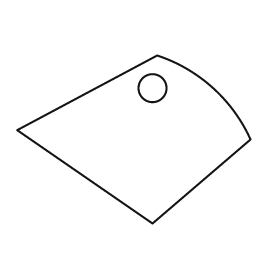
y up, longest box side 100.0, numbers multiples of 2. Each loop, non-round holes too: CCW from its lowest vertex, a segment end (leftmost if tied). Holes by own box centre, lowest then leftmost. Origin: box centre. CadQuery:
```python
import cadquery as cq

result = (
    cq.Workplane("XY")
    .moveTo(8.0, -36.0)
    .lineTo(50.0, 0.0)
    .threePointArc((34.0, 22.0), (10.0, 36.0))
    .lineTo(-50.0, 4.0)
    .close()
    .moveTo(8.0, 22.0)
    .circle(6.0)
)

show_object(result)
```